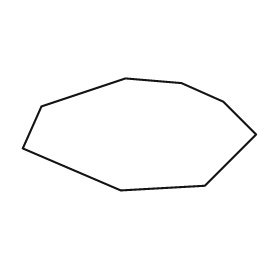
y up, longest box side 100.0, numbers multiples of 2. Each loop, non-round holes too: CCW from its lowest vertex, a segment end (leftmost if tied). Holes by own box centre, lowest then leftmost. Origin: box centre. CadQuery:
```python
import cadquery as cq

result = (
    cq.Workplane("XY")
    .moveTo(-8.0, -24.0)
    .lineTo(28.0, -22.0)
    .lineTo(50.0, 0.0)
    .lineTo(36.0, 14.0)
    .lineTo(18.0, 22.0)
    .lineTo(-6.0, 24.0)
    .lineTo(-42.0, 12.0)
    .lineTo(-50.0, -6.0)
    .close()
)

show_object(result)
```